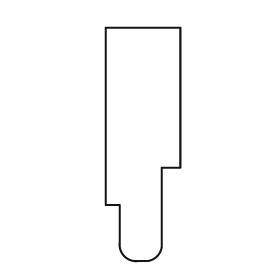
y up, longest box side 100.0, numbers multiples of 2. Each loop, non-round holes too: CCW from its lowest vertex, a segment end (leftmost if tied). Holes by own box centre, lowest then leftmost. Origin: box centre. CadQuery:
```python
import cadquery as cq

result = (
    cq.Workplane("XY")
    .moveTo(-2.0, -50.0)
    .lineTo(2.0, -50.0)
    .threePointArc((6.0, -48.0), (8.0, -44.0))
    .lineTo(8.0, -10.0)
    .lineTo(16.0, -10.0)
    .lineTo(16.0, 50.0)
    .lineTo(-16.0, 50.0)
    .lineTo(-16.0, -26.0)
    .lineTo(-10.0, -26.0)
    .lineTo(-10.0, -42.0)
    .threePointArc((-8.0, -48.0), (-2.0, -50.0))
    .close()
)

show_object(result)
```